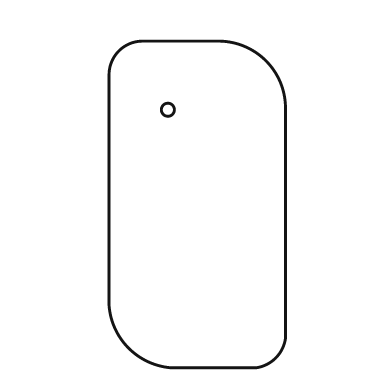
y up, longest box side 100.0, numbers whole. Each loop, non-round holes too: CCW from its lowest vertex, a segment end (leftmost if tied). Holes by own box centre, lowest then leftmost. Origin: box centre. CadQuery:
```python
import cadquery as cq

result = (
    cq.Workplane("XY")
    .moveTo(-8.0, -50.0)
    .lineTo(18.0, -50.0)
    .threePointArc((24.0, -47.0), (27.0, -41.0))
    .lineTo(27.0, 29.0)
    .threePointArc((21.0, 44.0), (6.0, 50.0))
    .lineTo(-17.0, 50.0)
    .threePointArc((-24.0, 47.0), (-27.0, 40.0))
    .lineTo(-27.0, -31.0)
    .threePointArc((-21.0, -44.0), (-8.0, -50.0))
    .close()
    .moveTo(-9.0, 29.0)
    .circle(2.0)
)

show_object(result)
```